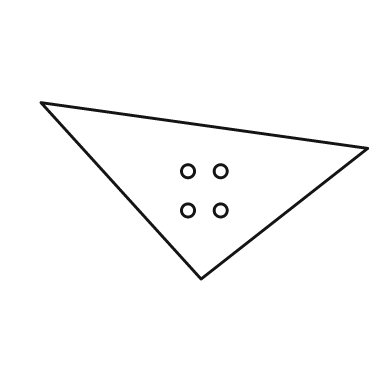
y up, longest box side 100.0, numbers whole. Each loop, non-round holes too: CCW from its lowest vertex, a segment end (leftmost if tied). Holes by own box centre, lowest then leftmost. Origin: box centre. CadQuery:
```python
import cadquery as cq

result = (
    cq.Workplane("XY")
    .moveTo(-1.0, -27.0)
    .lineTo(50.0, 13.0)
    .lineTo(-50.0, 27.0)
    .close()
    .moveTo(-5.0, -6.0)
    .circle(2.0)
    .moveTo(5.0, -6.0)
    .circle(2.0)
    .moveTo(-5.0, 6.0)
    .circle(2.0)
    .moveTo(5.0, 6.0)
    .circle(2.0)
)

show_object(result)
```